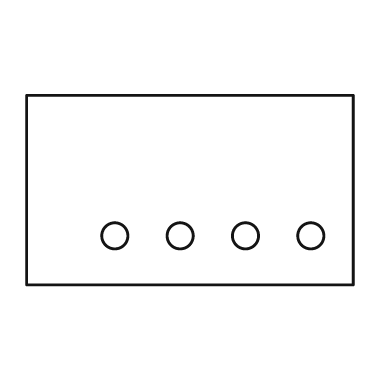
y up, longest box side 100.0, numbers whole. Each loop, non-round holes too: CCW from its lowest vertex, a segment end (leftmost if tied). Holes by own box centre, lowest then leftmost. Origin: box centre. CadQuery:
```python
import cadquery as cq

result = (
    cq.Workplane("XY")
    .moveTo(-50.0, -29.0)
    .lineTo(50.0, -29.0)
    .lineTo(50.0, 29.0)
    .lineTo(-50.0, 29.0)
    .close()
    .moveTo(-23.0, -14.0)
    .circle(4.0)
    .moveTo(-3.0, -14.0)
    .circle(4.0)
    .moveTo(17.0, -14.0)
    .circle(4.0)
    .moveTo(37.0, -14.0)
    .circle(4.0)
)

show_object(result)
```